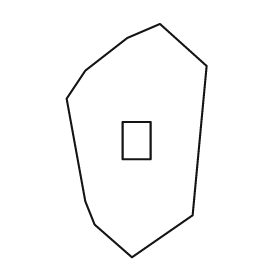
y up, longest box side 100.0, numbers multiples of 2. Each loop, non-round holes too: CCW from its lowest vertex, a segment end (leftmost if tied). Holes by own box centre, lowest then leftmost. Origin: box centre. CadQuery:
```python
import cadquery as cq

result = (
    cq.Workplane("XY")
    .moveTo(-2.0, -50.0)
    .lineTo(24.0, -32.0)
    .lineTo(30.0, 32.0)
    .lineTo(10.0, 50.0)
    .lineTo(-4.0, 44.0)
    .lineTo(-22.0, 30.0)
    .lineTo(-30.0, 18.0)
    .lineTo(-22.0, -26.0)
    .lineTo(-18.0, -36.0)
    .close()
    .moveTo(-6.0, -8.0)
    .lineTo(6.0, -8.0)
    .lineTo(6.0, 8.0)
    .lineTo(-6.0, 8.0)
    .close()
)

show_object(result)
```